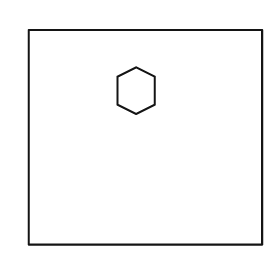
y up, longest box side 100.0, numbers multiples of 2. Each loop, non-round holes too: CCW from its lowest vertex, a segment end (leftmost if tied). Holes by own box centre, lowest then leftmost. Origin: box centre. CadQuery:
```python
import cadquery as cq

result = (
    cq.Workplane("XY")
    .moveTo(-50.0, -46.0)
    .lineTo(50.0, -46.0)
    .lineTo(50.0, 46.0)
    .lineTo(-50.0, 46.0)
    .close()
    .moveTo(-4.0, 10.0)
    .lineTo(4.0, 14.0)
    .lineTo(4.0, 26.0)
    .lineTo(-4.0, 30.0)
    .lineTo(-12.0, 26.0)
    .lineTo(-12.0, 14.0)
    .close()
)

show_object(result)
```